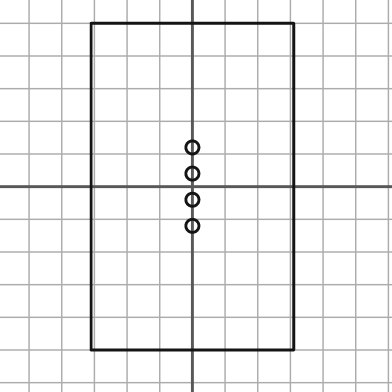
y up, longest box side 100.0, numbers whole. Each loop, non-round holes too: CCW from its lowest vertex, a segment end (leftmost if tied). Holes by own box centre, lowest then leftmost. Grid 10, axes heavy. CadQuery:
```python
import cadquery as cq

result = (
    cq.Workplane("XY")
    .moveTo(-31.0, -50.0)
    .lineTo(31.0, -50.0)
    .lineTo(31.0, 50.0)
    .lineTo(-31.0, 50.0)
    .close()
    .moveTo(0.0, -12.0)
    .circle(2.0)
    .moveTo(0.0, -4.0)
    .circle(2.0)
    .moveTo(0.0, 4.0)
    .circle(2.0)
    .moveTo(0.0, 12.0)
    .circle(2.0)
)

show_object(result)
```